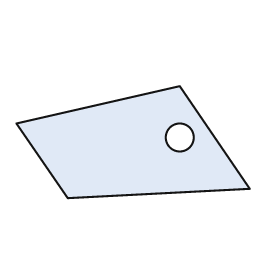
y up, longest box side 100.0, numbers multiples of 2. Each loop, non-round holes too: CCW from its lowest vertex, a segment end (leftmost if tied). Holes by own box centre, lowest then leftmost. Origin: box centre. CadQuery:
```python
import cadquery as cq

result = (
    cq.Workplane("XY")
    .moveTo(-28.0, -24.0)
    .lineTo(50.0, -20.0)
    .lineTo(20.0, 24.0)
    .lineTo(-50.0, 8.0)
    .close()
    .moveTo(20.0, 2.0)
    .circle(6.0)
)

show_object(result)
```